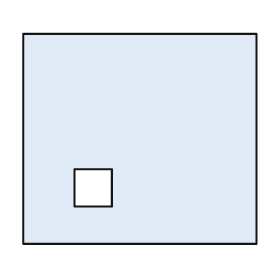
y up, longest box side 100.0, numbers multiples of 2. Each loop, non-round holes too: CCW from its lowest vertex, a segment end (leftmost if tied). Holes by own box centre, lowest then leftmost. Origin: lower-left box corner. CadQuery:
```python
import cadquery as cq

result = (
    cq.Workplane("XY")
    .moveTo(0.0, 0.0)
    .lineTo(100.0, 0.0)
    .lineTo(100.0, 90.0)
    .lineTo(0.0, 90.0)
    .close()
    .moveTo(22.0, 16.0)
    .lineTo(38.0, 16.0)
    .lineTo(38.0, 32.0)
    .lineTo(22.0, 32.0)
    .close()
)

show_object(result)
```